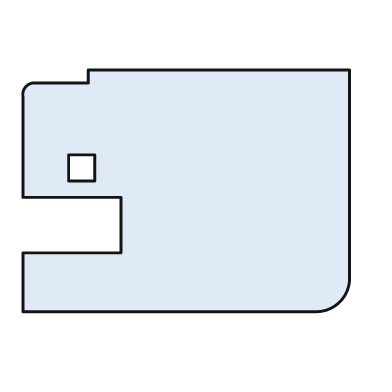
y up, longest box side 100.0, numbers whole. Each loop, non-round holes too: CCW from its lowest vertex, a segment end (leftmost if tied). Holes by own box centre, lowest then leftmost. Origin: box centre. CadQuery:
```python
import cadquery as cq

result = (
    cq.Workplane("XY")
    .moveTo(-50.0, -37.0)
    .lineTo(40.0, -37.0)
    .threePointArc((47.0, -34.0), (50.0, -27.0))
    .lineTo(50.0, 37.0)
    .lineTo(-30.0, 37.0)
    .lineTo(-30.0, 33.0)
    .lineTo(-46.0, 33.0)
    .threePointArc((-49.0, 32.0), (-50.0, 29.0))
    .lineTo(-50.0, -2.0)
    .lineTo(-20.0, -2.0)
    .lineTo(-20.0, -19.0)
    .lineTo(-50.0, -19.0)
    .close()
    .moveTo(-36.0, 3.0)
    .lineTo(-28.0, 3.0)
    .lineTo(-28.0, 11.0)
    .lineTo(-36.0, 11.0)
    .close()
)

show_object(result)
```